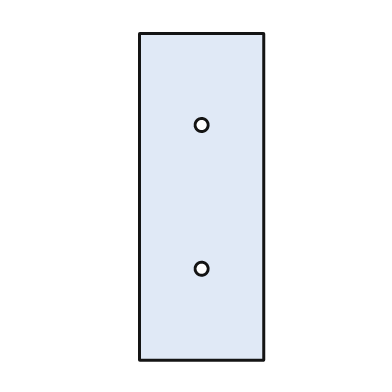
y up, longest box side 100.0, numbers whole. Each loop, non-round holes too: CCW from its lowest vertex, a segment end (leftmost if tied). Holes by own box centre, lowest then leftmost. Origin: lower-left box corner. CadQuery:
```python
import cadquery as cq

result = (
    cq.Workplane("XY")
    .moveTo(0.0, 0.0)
    .lineTo(38.0, 0.0)
    .lineTo(38.0, 100.0)
    .lineTo(0.0, 100.0)
    .close()
    .moveTo(19.0, 28.0)
    .circle(2.0)
    .moveTo(19.0, 72.0)
    .circle(2.0)
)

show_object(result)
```